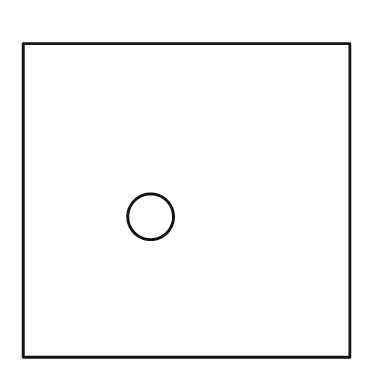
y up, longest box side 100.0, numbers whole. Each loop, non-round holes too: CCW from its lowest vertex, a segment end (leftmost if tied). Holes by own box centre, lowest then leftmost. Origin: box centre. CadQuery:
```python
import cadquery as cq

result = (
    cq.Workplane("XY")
    .moveTo(-50.0, -48.0)
    .lineTo(50.0, -48.0)
    .lineTo(50.0, 48.0)
    .lineTo(-50.0, 48.0)
    .close()
    .moveTo(-11.0, -5.0)
    .circle(7.0)
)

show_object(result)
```